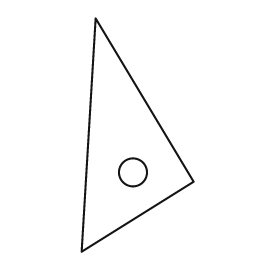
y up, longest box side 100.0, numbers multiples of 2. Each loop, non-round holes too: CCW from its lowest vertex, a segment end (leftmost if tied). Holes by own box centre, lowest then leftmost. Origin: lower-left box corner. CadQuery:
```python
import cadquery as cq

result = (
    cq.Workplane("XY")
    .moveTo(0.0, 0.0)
    .lineTo(48.0, 30.0)
    .lineTo(6.0, 100.0)
    .close()
    .moveTo(22.0, 34.0)
    .circle(6.0)
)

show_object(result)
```